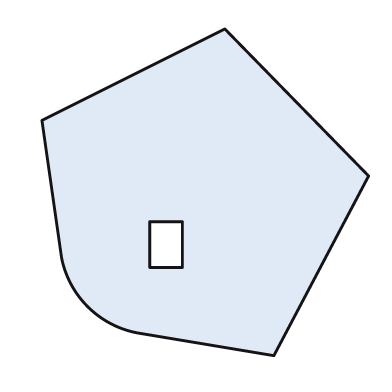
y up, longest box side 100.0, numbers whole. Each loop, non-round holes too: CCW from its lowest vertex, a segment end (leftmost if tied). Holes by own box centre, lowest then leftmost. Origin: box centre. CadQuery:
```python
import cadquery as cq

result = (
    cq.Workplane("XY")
    .moveTo(21.0, -50.0)
    .lineTo(50.0, 5.0)
    .lineTo(6.0, 50.0)
    .lineTo(-50.0, 22.0)
    .lineTo(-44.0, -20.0)
    .threePointArc((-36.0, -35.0), (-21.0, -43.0))
    .close()
    .moveTo(-17.0, -23.0)
    .lineTo(-7.0, -23.0)
    .lineTo(-7.0, -9.0)
    .lineTo(-17.0, -9.0)
    .close()
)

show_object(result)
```